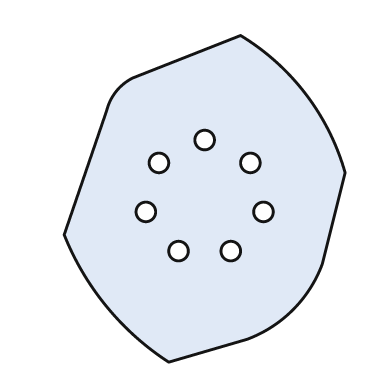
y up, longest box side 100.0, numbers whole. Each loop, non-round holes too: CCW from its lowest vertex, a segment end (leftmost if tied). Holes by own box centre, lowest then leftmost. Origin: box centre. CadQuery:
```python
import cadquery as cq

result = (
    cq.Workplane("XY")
    .moveTo(-11.0, -50.0)
    .lineTo(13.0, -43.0)
    .threePointArc((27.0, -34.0), (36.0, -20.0))
    .lineTo(43.0, 8.0)
    .threePointArc((31.0, 32.0), (11.0, 50.0))
    .lineTo(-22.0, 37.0)
    .threePointArc((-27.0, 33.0), (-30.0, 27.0))
    .lineTo(-43.0, -11.0)
    .threePointArc((-30.0, -33.0), (-11.0, -50.0))
    .close()
    .moveTo(-8.0, -16.0)
    .circle(3.0)
    .moveTo(8.0, -16.0)
    .circle(3.0)
    .moveTo(-18.0, -4.0)
    .circle(3.0)
    .moveTo(18.0, -4.0)
    .circle(3.0)
    .moveTo(-14.0, 11.0)
    .circle(3.0)
    .moveTo(14.0, 11.0)
    .circle(3.0)
    .moveTo(0.0, 18.0)
    .circle(3.0)
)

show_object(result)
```